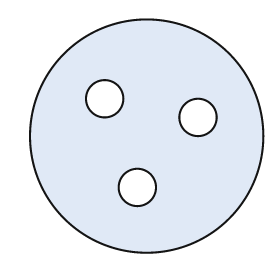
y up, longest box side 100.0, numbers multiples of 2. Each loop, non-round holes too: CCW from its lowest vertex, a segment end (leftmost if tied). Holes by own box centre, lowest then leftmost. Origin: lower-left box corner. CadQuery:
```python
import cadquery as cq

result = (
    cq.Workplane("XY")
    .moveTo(50.0, 50.0)
    .circle(50.0)
    .moveTo(46.0, 28.0)
    .circle(8.0)
    .moveTo(72.0, 58.0)
    .circle(8.0)
    .moveTo(32.0, 66.0)
    .circle(8.0)
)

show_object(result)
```